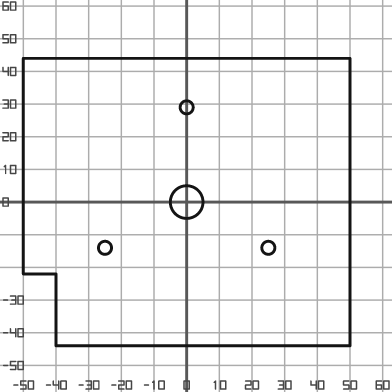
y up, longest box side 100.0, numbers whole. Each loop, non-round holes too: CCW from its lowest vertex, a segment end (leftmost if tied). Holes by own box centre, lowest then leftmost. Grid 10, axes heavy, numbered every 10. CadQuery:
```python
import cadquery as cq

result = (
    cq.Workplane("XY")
    .moveTo(-40.0, -44.0)
    .lineTo(50.0, -44.0)
    .lineTo(50.0, 44.0)
    .lineTo(-50.0, 44.0)
    .lineTo(-50.0, -22.0)
    .lineTo(-40.0, -22.0)
    .close()
    .moveTo(-25.0, -14.0)
    .circle(2.0)
    .moveTo(25.0, -14.0)
    .circle(2.0)
    .moveTo(0.0, 0.0)
    .circle(5.0)
    .moveTo(0.0, 29.0)
    .circle(2.0)
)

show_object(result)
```